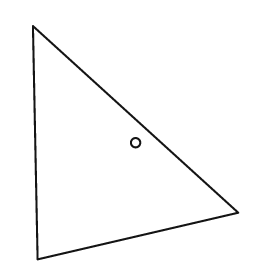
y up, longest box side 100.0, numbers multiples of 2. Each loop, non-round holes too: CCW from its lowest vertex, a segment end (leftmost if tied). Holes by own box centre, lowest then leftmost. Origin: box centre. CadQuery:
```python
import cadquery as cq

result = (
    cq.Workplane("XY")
    .moveTo(-42.0, -50.0)
    .lineTo(44.0, -30.0)
    .lineTo(-44.0, 50.0)
    .close()
    .moveTo(0.0, 0.0)
    .circle(2.0)
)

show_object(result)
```